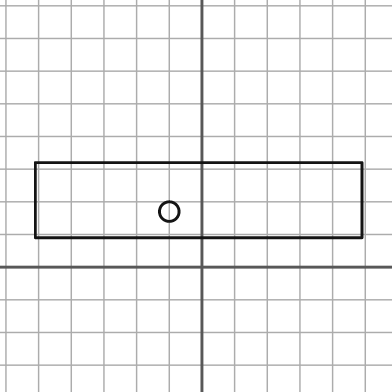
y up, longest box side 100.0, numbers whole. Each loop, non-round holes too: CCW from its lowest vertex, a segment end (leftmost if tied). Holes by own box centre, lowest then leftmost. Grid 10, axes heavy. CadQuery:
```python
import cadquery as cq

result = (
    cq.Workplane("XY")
    .moveTo(-51.0, 9.0)
    .lineTo(49.0, 9.0)
    .lineTo(49.0, 32.0)
    .lineTo(-51.0, 32.0)
    .close()
    .moveTo(-10.0, 17.0)
    .circle(3.0)
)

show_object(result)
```